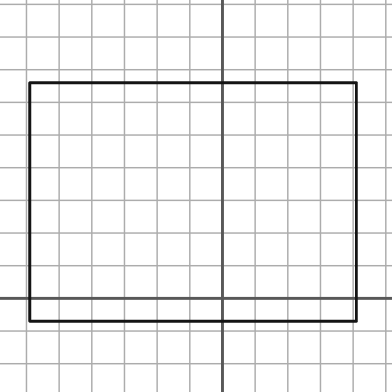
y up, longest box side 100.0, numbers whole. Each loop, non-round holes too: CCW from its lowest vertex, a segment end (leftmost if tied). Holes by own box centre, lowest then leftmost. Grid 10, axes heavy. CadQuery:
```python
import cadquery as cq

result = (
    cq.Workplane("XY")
    .moveTo(-59.0, -7.0)
    .lineTo(41.0, -7.0)
    .lineTo(41.0, 66.0)
    .lineTo(-59.0, 66.0)
    .close()
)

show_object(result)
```